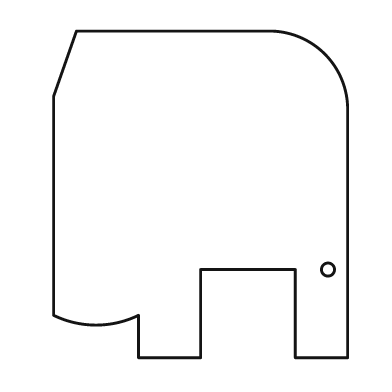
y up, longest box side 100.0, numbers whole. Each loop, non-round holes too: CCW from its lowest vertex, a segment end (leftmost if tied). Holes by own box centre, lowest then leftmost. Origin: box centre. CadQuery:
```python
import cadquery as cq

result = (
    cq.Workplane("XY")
    .moveTo(-19.0, -50.0)
    .lineTo(0.0, -50.0)
    .lineTo(0.0, -23.0)
    .lineTo(29.0, -23.0)
    .lineTo(29.0, -50.0)
    .lineTo(45.0, -50.0)
    .lineTo(45.0, 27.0)
    .threePointArc((38.0, 43.0), (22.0, 50.0))
    .lineTo(-38.0, 50.0)
    .lineTo(-45.0, 30.0)
    .lineTo(-45.0, -37.0)
    .threePointArc((-32.0, -40.0), (-19.0, -37.0))
    .close()
    .moveTo(39.0, -23.0)
    .circle(2.0)
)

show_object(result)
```